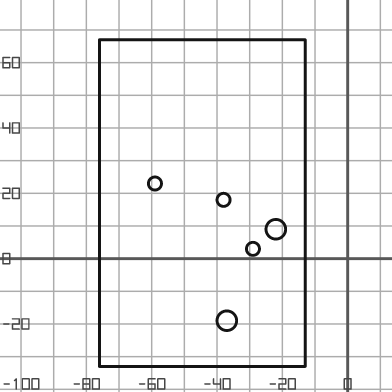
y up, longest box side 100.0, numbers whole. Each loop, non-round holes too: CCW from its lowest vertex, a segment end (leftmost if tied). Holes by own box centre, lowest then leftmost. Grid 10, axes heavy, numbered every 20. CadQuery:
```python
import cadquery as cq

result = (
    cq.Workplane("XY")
    .moveTo(-76.0, -33.0)
    .lineTo(-13.0, -33.0)
    .lineTo(-13.0, 67.0)
    .lineTo(-76.0, 67.0)
    .close()
    .moveTo(-37.0, -19.0)
    .circle(3.0)
    .moveTo(-29.0, 3.0)
    .circle(2.0)
    .moveTo(-22.0, 9.0)
    .circle(3.0)
    .moveTo(-38.0, 18.0)
    .circle(2.0)
    .moveTo(-59.0, 23.0)
    .circle(2.0)
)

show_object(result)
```